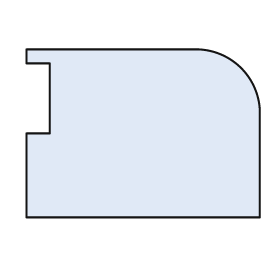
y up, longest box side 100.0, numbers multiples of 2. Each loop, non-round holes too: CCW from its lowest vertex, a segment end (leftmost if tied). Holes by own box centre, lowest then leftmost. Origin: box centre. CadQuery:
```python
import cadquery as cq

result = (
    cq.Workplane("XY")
    .moveTo(-50.0, -36.0)
    .lineTo(50.0, -36.0)
    .lineTo(50.0, 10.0)
    .threePointArc((42.0, 28.0), (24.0, 36.0))
    .lineTo(-50.0, 36.0)
    .lineTo(-50.0, 30.0)
    .lineTo(-40.0, 30.0)
    .lineTo(-40.0, 0.0)
    .lineTo(-50.0, 0.0)
    .close()
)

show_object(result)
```